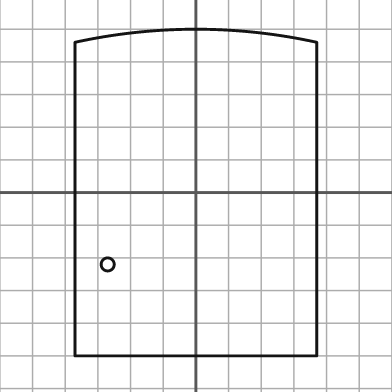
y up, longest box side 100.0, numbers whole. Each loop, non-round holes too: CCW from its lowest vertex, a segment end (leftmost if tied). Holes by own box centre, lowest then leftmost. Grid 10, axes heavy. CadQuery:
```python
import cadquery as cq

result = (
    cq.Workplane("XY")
    .moveTo(-37.0, -50.0)
    .lineTo(37.0, -50.0)
    .lineTo(37.0, 46.0)
    .threePointArc((0.0, 50.0), (-37.0, 46.0))
    .close()
    .moveTo(-27.0, -22.0)
    .circle(2.0)
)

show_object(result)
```